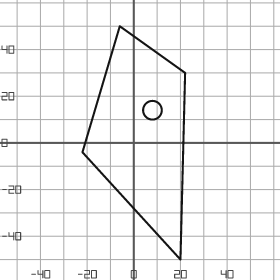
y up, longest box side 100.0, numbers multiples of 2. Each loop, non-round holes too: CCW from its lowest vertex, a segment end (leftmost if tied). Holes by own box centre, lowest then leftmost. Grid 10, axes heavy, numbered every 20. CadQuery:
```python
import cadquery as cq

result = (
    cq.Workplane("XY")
    .moveTo(20.0, -50.0)
    .lineTo(22.0, 30.0)
    .lineTo(-6.0, 50.0)
    .lineTo(-22.0, -4.0)
    .close()
    .moveTo(8.0, 14.0)
    .circle(4.0)
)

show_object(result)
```